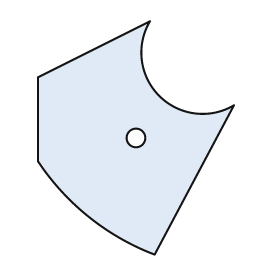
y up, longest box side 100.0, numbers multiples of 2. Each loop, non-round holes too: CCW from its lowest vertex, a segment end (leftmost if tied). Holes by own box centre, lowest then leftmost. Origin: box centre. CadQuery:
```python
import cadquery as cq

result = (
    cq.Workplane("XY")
    .moveTo(8.0, -50.0)
    .lineTo(42.0, 14.0)
    .threePointArc((10.0, 18.0), (6.0, 50.0))
    .lineTo(-42.0, 26.0)
    .lineTo(-42.0, -10.0)
    .threePointArc((-20.0, -34.0), (8.0, -50.0))
    .close()
    .moveTo(0.0, 0.0)
    .circle(4.0)
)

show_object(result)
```